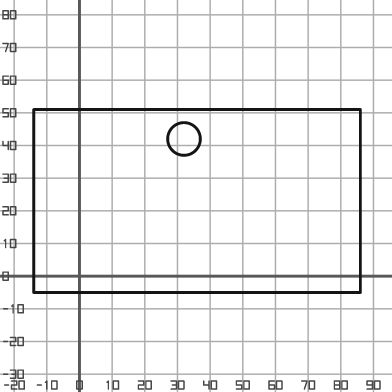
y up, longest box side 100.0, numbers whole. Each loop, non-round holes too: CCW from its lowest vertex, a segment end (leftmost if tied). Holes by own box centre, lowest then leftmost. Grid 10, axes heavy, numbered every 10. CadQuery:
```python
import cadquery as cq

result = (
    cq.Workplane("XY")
    .moveTo(-14.0, -5.0)
    .lineTo(86.0, -5.0)
    .lineTo(86.0, 51.0)
    .lineTo(-14.0, 51.0)
    .close()
    .moveTo(32.0, 42.0)
    .circle(5.0)
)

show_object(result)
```